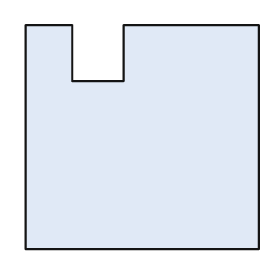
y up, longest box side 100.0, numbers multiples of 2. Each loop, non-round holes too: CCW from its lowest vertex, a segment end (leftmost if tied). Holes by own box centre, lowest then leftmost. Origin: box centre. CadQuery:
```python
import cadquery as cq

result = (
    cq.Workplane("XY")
    .moveTo(-50.0, -48.0)
    .lineTo(50.0, -48.0)
    .lineTo(50.0, 48.0)
    .lineTo(-8.0, 48.0)
    .lineTo(-8.0, 24.0)
    .lineTo(-30.0, 24.0)
    .lineTo(-30.0, 48.0)
    .lineTo(-50.0, 48.0)
    .close()
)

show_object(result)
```